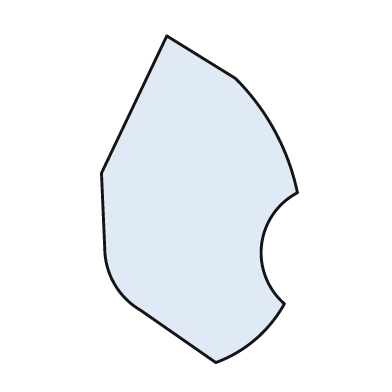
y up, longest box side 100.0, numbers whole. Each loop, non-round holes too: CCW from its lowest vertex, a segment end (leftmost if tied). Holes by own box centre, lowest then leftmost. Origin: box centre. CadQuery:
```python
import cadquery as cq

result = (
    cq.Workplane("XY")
    .moveTo(5.0, -50.0)
    .threePointArc((17.0, -43.0), (26.0, -32.0))
    .threePointArc((19.0, -14.0), (30.0, 2.0))
    .threePointArc((23.0, 21.0), (11.0, 37.0))
    .lineTo(-10.0, 50.0)
    .lineTo(-30.0, 8.0)
    .lineTo(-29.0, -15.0)
    .threePointArc((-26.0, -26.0), (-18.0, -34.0))
    .close()
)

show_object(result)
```